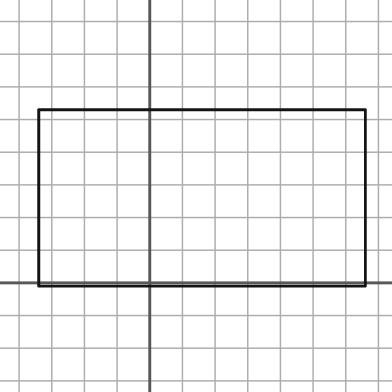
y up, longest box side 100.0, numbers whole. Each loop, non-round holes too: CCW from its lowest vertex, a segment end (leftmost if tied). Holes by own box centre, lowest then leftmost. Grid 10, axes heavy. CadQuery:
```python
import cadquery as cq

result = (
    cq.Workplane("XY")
    .moveTo(-34.0, -1.0)
    .lineTo(66.0, -1.0)
    .lineTo(66.0, 53.0)
    .lineTo(-34.0, 53.0)
    .close()
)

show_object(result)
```